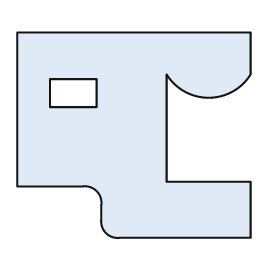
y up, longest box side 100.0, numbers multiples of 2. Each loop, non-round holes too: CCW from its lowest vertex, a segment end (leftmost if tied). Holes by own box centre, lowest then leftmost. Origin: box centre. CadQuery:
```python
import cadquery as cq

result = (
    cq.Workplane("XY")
    .moveTo(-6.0, -44.0)
    .lineTo(50.0, -44.0)
    .lineTo(50.0, -20.0)
    .lineTo(14.0, -20.0)
    .lineTo(14.0, 26.0)
    .threePointArc((32.0, 16.0), (50.0, 26.0))
    .lineTo(50.0, 44.0)
    .lineTo(-50.0, 44.0)
    .lineTo(-50.0, -22.0)
    .lineTo(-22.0, -22.0)
    .threePointArc((-16.0, -24.0), (-14.0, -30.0))
    .lineTo(-14.0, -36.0)
    .threePointArc((-12.0, -42.0), (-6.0, -44.0))
    .close()
    .moveTo(-36.0, 12.0)
    .lineTo(-16.0, 12.0)
    .lineTo(-16.0, 24.0)
    .lineTo(-36.0, 24.0)
    .close()
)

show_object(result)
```